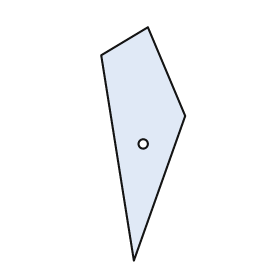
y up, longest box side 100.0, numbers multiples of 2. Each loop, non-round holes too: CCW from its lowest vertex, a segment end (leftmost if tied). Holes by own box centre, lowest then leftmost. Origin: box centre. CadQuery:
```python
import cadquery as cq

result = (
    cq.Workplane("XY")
    .moveTo(-4.0, -50.0)
    .lineTo(18.0, 12.0)
    .lineTo(2.0, 50.0)
    .lineTo(-18.0, 38.0)
    .close()
    .moveTo(0.0, 0.0)
    .circle(2.0)
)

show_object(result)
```